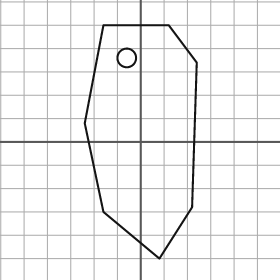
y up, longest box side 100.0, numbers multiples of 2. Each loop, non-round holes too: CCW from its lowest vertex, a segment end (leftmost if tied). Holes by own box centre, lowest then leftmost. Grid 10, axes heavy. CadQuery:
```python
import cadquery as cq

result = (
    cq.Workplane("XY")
    .moveTo(8.0, -50.0)
    .lineTo(22.0, -28.0)
    .lineTo(24.0, 34.0)
    .lineTo(12.0, 50.0)
    .lineTo(-16.0, 50.0)
    .lineTo(-24.0, 8.0)
    .lineTo(-16.0, -30.0)
    .close()
    .moveTo(-6.0, 36.0)
    .circle(4.0)
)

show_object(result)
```